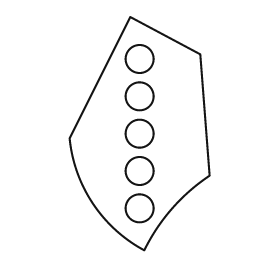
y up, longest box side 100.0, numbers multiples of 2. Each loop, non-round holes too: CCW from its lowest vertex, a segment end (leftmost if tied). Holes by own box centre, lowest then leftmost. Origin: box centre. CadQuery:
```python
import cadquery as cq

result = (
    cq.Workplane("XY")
    .moveTo(2.0, -50.0)
    .threePointArc((14.0, -32.0), (30.0, -18.0))
    .lineTo(26.0, 34.0)
    .lineTo(-4.0, 50.0)
    .lineTo(-30.0, -2.0)
    .threePointArc((-20.0, -30.0), (2.0, -50.0))
    .close()
    .moveTo(0.0, -32.0)
    .circle(6.0)
    .moveTo(0.0, -16.0)
    .circle(6.0)
    .moveTo(0.0, 0.0)
    .circle(6.0)
    .moveTo(0.0, 16.0)
    .circle(6.0)
    .moveTo(0.0, 32.0)
    .circle(6.0)
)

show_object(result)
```